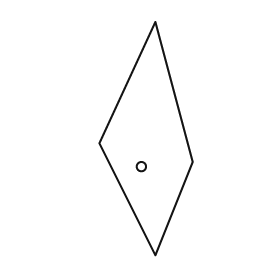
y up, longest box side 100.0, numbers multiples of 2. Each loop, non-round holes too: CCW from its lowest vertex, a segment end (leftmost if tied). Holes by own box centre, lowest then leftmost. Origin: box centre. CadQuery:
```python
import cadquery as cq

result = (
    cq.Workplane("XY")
    .moveTo(4.0, -50.0)
    .lineTo(20.0, -10.0)
    .lineTo(4.0, 50.0)
    .lineTo(-20.0, -2.0)
    .close()
    .moveTo(-2.0, -12.0)
    .circle(2.0)
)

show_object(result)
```